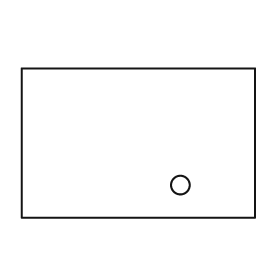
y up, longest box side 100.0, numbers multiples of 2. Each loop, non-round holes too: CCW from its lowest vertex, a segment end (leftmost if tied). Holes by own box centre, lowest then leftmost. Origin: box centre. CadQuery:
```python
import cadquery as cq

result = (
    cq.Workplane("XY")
    .moveTo(-50.0, -32.0)
    .lineTo(50.0, -32.0)
    .lineTo(50.0, 32.0)
    .lineTo(-50.0, 32.0)
    .close()
    .moveTo(18.0, -18.0)
    .circle(4.0)
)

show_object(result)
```